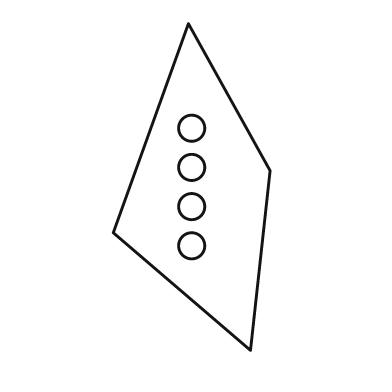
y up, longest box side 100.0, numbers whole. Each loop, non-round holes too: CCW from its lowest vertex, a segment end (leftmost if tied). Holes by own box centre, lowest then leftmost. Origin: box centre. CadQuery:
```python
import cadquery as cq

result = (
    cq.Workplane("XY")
    .moveTo(18.0, -50.0)
    .lineTo(24.0, 5.0)
    .lineTo(-1.0, 50.0)
    .lineTo(-24.0, -14.0)
    .close()
    .moveTo(0.0, -18.0)
    .circle(4.0)
    .moveTo(0.0, -6.0)
    .circle(4.0)
    .moveTo(0.0, 6.0)
    .circle(4.0)
    .moveTo(0.0, 18.0)
    .circle(4.0)
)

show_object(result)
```